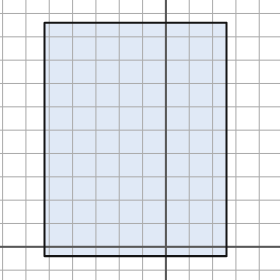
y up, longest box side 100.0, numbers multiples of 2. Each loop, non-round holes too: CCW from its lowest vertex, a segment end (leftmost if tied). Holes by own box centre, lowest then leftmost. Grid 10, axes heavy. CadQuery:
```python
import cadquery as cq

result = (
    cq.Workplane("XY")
    .moveTo(-52.0, -4.0)
    .lineTo(26.0, -4.0)
    .lineTo(26.0, 96.0)
    .lineTo(-52.0, 96.0)
    .close()
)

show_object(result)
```